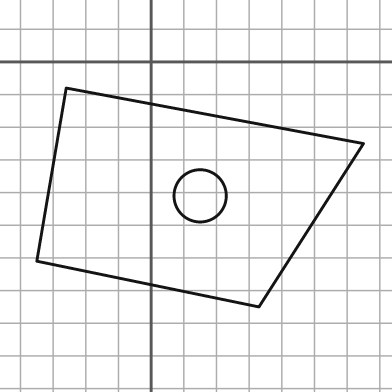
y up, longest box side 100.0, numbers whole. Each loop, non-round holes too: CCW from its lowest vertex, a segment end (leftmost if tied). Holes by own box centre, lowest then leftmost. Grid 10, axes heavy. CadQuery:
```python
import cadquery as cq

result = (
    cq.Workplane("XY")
    .moveTo(33.0, -75.0)
    .lineTo(65.0, -25.0)
    .lineTo(-26.0, -8.0)
    .lineTo(-35.0, -61.0)
    .close()
    .moveTo(15.0, -41.0)
    .circle(8.0)
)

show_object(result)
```